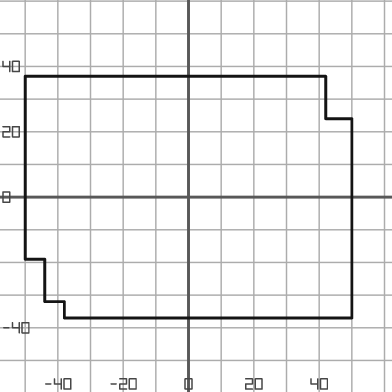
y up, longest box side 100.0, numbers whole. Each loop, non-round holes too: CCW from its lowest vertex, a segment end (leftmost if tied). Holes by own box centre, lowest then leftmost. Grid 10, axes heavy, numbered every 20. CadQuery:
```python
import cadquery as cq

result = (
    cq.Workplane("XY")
    .moveTo(-38.0, -37.0)
    .lineTo(50.0, -37.0)
    .lineTo(50.0, 24.0)
    .lineTo(42.0, 24.0)
    .lineTo(42.0, 37.0)
    .lineTo(-50.0, 37.0)
    .lineTo(-50.0, -19.0)
    .lineTo(-44.0, -19.0)
    .lineTo(-44.0, -32.0)
    .lineTo(-38.0, -32.0)
    .close()
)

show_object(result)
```